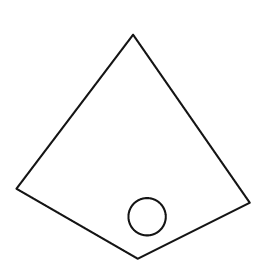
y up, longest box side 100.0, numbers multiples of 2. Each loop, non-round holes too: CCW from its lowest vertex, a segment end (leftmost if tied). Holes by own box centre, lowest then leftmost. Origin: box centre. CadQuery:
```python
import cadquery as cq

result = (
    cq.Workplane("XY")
    .moveTo(2.0, -48.0)
    .lineTo(50.0, -24.0)
    .lineTo(0.0, 48.0)
    .lineTo(-50.0, -18.0)
    .close()
    .moveTo(6.0, -30.0)
    .circle(8.0)
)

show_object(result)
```